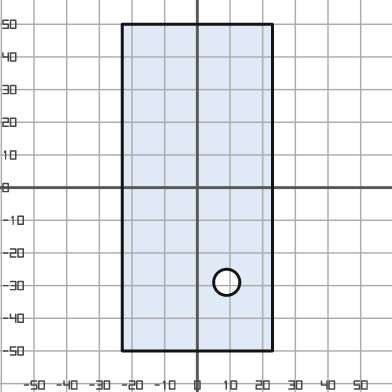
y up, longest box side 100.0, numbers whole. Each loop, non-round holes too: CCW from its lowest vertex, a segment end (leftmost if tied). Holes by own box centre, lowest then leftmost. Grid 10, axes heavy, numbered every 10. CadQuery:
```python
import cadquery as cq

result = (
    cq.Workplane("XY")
    .moveTo(-23.0, -50.0)
    .lineTo(23.0, -50.0)
    .lineTo(23.0, 50.0)
    .lineTo(-23.0, 50.0)
    .close()
    .moveTo(9.0, -29.0)
    .circle(4.0)
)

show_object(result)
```